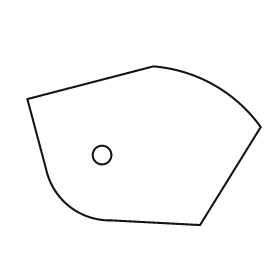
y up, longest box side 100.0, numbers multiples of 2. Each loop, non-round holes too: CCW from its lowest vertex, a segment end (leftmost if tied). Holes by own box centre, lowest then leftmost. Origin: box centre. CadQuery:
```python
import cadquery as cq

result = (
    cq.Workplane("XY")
    .moveTo(24.0, -34.0)
    .lineTo(50.0, 8.0)
    .threePointArc((30.0, 26.0), (4.0, 34.0))
    .lineTo(-50.0, 20.0)
    .lineTo(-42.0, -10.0)
    .threePointArc((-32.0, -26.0), (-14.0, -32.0))
    .close()
    .moveTo(-18.0, -4.0)
    .circle(4.0)
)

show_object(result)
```